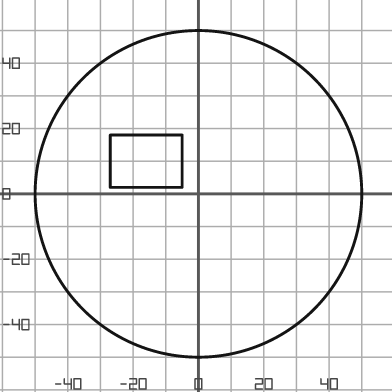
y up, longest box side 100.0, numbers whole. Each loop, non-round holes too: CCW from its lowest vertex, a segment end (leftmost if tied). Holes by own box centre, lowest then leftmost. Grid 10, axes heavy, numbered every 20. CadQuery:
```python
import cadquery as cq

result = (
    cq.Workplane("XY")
    .moveTo(0.0, 0.0)
    .circle(50.0)
    .moveTo(-27.0, 2.0)
    .lineTo(-5.0, 2.0)
    .lineTo(-5.0, 18.0)
    .lineTo(-27.0, 18.0)
    .close()
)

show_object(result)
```